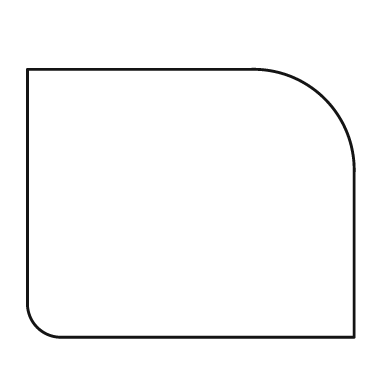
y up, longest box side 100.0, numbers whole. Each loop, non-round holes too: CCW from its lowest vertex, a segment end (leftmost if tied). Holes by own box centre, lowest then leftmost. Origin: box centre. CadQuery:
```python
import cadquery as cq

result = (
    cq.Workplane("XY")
    .moveTo(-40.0, -41.0)
    .lineTo(50.0, -41.0)
    .lineTo(50.0, 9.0)
    .threePointArc((41.0, 32.0), (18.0, 41.0))
    .lineTo(-50.0, 41.0)
    .lineTo(-50.0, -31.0)
    .threePointArc((-47.0, -38.0), (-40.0, -41.0))
    .close()
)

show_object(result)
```